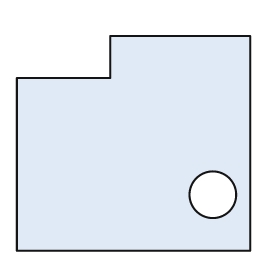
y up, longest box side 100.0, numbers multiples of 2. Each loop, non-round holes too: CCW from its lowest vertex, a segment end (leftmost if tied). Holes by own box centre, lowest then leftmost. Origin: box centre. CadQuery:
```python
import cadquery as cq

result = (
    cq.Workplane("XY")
    .moveTo(-50.0, -46.0)
    .lineTo(50.0, -46.0)
    .lineTo(50.0, 46.0)
    .lineTo(-10.0, 46.0)
    .lineTo(-10.0, 28.0)
    .lineTo(-50.0, 28.0)
    .close()
    .moveTo(34.0, -22.0)
    .circle(10.0)
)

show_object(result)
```